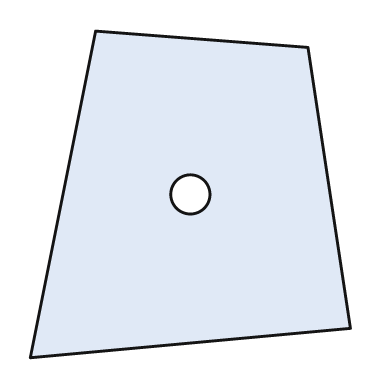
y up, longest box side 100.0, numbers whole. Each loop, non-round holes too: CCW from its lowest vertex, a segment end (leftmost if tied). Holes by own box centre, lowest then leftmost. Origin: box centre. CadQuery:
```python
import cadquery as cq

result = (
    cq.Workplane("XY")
    .moveTo(-49.0, -50.0)
    .lineTo(49.0, -41.0)
    .lineTo(36.0, 45.0)
    .lineTo(-29.0, 50.0)
    .close()
    .moveTo(0.0, 0.0)
    .circle(6.0)
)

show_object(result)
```